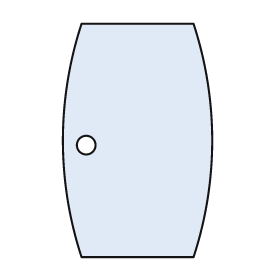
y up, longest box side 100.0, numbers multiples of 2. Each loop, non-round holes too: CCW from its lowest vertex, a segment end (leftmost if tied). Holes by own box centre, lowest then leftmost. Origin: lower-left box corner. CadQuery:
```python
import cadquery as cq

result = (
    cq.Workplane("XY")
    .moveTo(8.0, 0.0)
    .lineTo(56.0, 0.0)
    .threePointArc((64.0, 50.0), (56.0, 100.0))
    .lineTo(8.0, 100.0)
    .threePointArc((0.0, 50.0), (8.0, 0.0))
    .close()
    .moveTo(10.0, 48.0)
    .circle(4.0)
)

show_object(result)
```